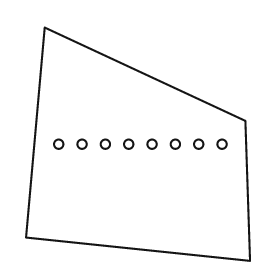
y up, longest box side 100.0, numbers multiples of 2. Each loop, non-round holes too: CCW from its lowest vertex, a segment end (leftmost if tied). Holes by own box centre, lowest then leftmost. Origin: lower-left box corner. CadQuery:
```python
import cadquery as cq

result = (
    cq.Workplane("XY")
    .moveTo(96.0, 0.0)
    .lineTo(94.0, 60.0)
    .lineTo(8.0, 100.0)
    .lineTo(0.0, 10.0)
    .close()
    .moveTo(14.0, 50.0)
    .circle(2.0)
    .moveTo(24.0, 50.0)
    .circle(2.0)
    .moveTo(34.0, 50.0)
    .circle(2.0)
    .moveTo(44.0, 50.0)
    .circle(2.0)
    .moveTo(54.0, 50.0)
    .circle(2.0)
    .moveTo(64.0, 50.0)
    .circle(2.0)
    .moveTo(74.0, 50.0)
    .circle(2.0)
    .moveTo(84.0, 50.0)
    .circle(2.0)
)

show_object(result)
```